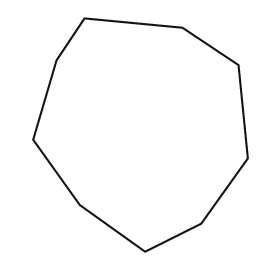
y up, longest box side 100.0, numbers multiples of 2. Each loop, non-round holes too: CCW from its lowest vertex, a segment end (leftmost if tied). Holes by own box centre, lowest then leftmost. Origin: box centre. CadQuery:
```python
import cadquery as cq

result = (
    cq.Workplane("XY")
    .moveTo(2.0, -50.0)
    .lineTo(26.0, -38.0)
    .lineTo(46.0, -10.0)
    .lineTo(42.0, 30.0)
    .lineTo(18.0, 46.0)
    .lineTo(-24.0, 50.0)
    .lineTo(-36.0, 32.0)
    .lineTo(-46.0, -2.0)
    .lineTo(-26.0, -30.0)
    .close()
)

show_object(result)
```